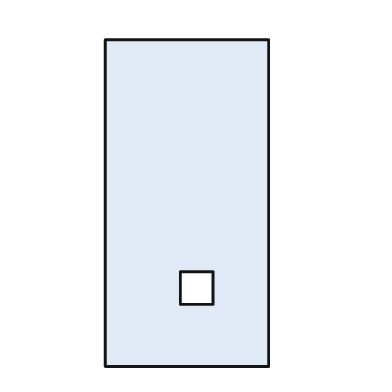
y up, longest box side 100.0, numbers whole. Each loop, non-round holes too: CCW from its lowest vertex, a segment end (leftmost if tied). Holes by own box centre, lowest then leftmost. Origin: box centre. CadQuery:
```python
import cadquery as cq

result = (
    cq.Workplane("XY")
    .moveTo(-25.0, -50.0)
    .lineTo(25.0, -50.0)
    .lineTo(25.0, 50.0)
    .lineTo(-25.0, 50.0)
    .close()
    .moveTo(-2.0, -31.0)
    .lineTo(8.0, -31.0)
    .lineTo(8.0, -21.0)
    .lineTo(-2.0, -21.0)
    .close()
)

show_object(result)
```